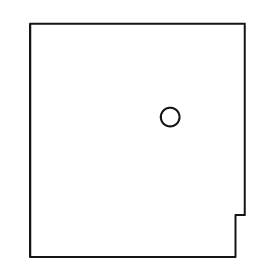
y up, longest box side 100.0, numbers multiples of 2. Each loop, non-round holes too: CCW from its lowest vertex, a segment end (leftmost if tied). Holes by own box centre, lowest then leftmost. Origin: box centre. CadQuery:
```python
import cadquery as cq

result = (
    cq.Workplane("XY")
    .moveTo(-46.0, -50.0)
    .lineTo(42.0, -50.0)
    .lineTo(42.0, -32.0)
    .lineTo(46.0, -32.0)
    .lineTo(46.0, 50.0)
    .lineTo(-46.0, 50.0)
    .close()
    .moveTo(14.0, 10.0)
    .circle(4.0)
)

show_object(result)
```